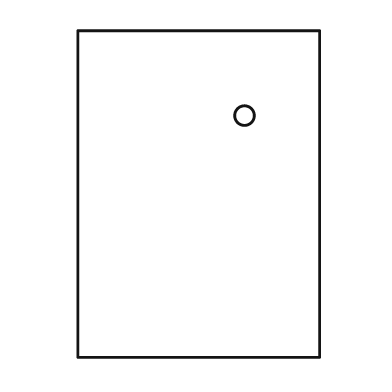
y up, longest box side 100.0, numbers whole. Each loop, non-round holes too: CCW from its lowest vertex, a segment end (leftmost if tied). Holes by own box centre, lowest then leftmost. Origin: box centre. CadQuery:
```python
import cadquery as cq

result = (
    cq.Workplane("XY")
    .moveTo(-37.0, -50.0)
    .lineTo(37.0, -50.0)
    .lineTo(37.0, 50.0)
    .lineTo(-37.0, 50.0)
    .close()
    .moveTo(14.0, 24.0)
    .circle(3.0)
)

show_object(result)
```